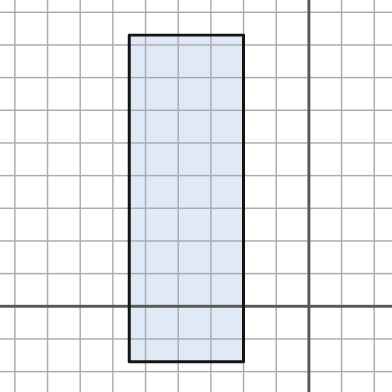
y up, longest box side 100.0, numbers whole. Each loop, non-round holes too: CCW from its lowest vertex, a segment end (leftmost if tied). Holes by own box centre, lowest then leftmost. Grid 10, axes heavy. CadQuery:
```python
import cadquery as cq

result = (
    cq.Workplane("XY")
    .moveTo(-55.0, -17.0)
    .lineTo(-20.0, -17.0)
    .lineTo(-20.0, 83.0)
    .lineTo(-55.0, 83.0)
    .close()
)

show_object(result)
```